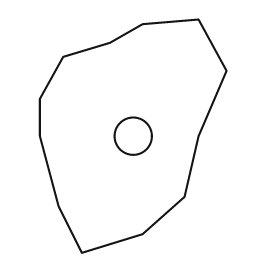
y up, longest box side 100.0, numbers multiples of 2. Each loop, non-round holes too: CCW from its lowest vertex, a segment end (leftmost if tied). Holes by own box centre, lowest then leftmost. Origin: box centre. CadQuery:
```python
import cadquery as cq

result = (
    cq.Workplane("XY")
    .moveTo(-22.0, -50.0)
    .lineTo(4.0, -42.0)
    .lineTo(22.0, -26.0)
    .lineTo(28.0, 0.0)
    .lineTo(40.0, 28.0)
    .lineTo(28.0, 50.0)
    .lineTo(4.0, 48.0)
    .lineTo(-10.0, 40.0)
    .lineTo(-30.0, 34.0)
    .lineTo(-40.0, 16.0)
    .lineTo(-40.0, 0.0)
    .lineTo(-32.0, -30.0)
    .close()
    .moveTo(0.0, 0.0)
    .circle(8.0)
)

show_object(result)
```